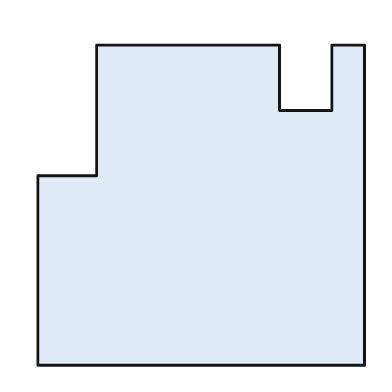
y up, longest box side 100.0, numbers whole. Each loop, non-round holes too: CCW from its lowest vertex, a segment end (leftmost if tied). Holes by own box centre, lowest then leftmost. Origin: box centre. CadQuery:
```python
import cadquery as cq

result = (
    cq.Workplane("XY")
    .moveTo(-50.0, -49.0)
    .lineTo(50.0, -49.0)
    .lineTo(50.0, 49.0)
    .lineTo(40.0, 49.0)
    .lineTo(40.0, 29.0)
    .lineTo(24.0, 29.0)
    .lineTo(24.0, 49.0)
    .lineTo(-32.0, 49.0)
    .lineTo(-32.0, 9.0)
    .lineTo(-50.0, 9.0)
    .close()
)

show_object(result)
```